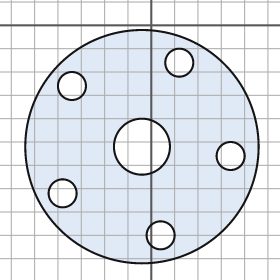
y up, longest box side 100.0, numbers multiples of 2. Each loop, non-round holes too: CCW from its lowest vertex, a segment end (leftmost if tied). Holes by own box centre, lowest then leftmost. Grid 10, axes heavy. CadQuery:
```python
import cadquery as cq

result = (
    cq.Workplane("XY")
    .moveTo(-4.0, -52.0)
    .circle(50.0)
    .moveTo(4.0, -90.0)
    .circle(6.0)
    .moveTo(-38.0, -72.0)
    .circle(6.0)
    .moveTo(34.0, -56.0)
    .circle(6.0)
    .moveTo(-4.0, -52.0)
    .circle(12.0)
    .moveTo(-34.0, -26.0)
    .circle(6.0)
    .moveTo(12.0, -16.0)
    .circle(6.0)
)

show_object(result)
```